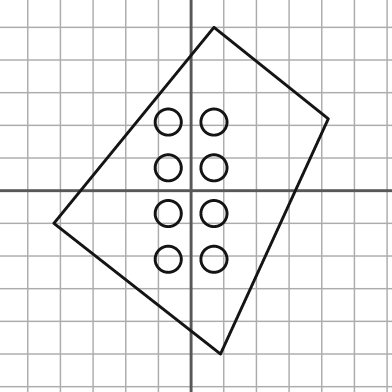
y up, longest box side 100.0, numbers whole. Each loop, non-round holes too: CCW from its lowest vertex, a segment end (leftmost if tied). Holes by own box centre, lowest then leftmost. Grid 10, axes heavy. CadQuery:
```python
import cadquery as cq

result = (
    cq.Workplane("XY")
    .moveTo(9.0, -50.0)
    .lineTo(42.0, 22.0)
    .lineTo(7.0, 50.0)
    .lineTo(-42.0, -10.0)
    .close()
    .moveTo(-7.0, -21.0)
    .circle(4.0)
    .moveTo(7.0, -21.0)
    .circle(4.0)
    .moveTo(-7.0, -7.0)
    .circle(4.0)
    .moveTo(7.0, -7.0)
    .circle(4.0)
    .moveTo(-7.0, 7.0)
    .circle(4.0)
    .moveTo(7.0, 7.0)
    .circle(4.0)
    .moveTo(-7.0, 21.0)
    .circle(4.0)
    .moveTo(7.0, 21.0)
    .circle(4.0)
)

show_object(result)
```